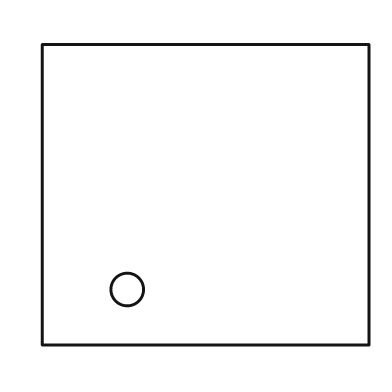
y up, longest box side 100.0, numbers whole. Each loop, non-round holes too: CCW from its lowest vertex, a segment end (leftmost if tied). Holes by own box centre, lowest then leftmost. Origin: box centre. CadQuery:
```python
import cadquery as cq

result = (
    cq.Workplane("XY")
    .moveTo(-50.0, -46.0)
    .lineTo(50.0, -46.0)
    .lineTo(50.0, 46.0)
    .lineTo(-50.0, 46.0)
    .close()
    .moveTo(-24.0, -29.0)
    .circle(5.0)
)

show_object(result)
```